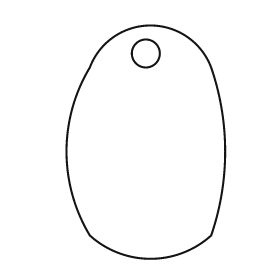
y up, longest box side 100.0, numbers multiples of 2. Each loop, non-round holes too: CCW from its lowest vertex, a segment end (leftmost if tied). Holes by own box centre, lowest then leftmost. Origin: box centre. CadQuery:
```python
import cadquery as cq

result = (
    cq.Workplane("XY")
    .moveTo(-24.0, -40.0)
    .threePointArc((2.0, -50.0), (28.0, -40.0))
    .threePointArc((34.0, -4.0), (28.0, 32.0))
    .threePointArc((2.0, 50.0), (-24.0, 32.0))
    .threePointArc((-34.0, -4.0), (-24.0, -40.0))
    .close()
    .moveTo(0.0, 38.0)
    .circle(6.0)
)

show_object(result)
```